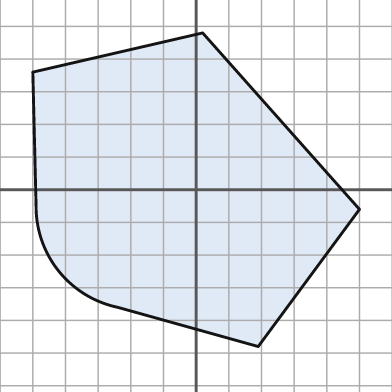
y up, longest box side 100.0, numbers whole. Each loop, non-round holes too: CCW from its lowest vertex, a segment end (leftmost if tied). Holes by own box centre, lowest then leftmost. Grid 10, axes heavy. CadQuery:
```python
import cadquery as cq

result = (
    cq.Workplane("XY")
    .moveTo(19.0, -48.0)
    .lineTo(50.0, -6.0)
    .lineTo(2.0, 48.0)
    .lineTo(-50.0, 36.0)
    .lineTo(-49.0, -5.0)
    .threePointArc((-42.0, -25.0), (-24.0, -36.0))
    .close()
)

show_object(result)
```